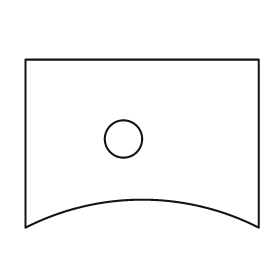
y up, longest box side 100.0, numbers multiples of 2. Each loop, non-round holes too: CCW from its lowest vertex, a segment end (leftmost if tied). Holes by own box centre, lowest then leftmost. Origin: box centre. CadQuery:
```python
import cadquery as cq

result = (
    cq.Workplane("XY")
    .moveTo(-50.0, -36.0)
    .threePointArc((0.0, -24.0), (50.0, -36.0))
    .lineTo(50.0, 36.0)
    .lineTo(-50.0, 36.0)
    .close()
    .moveTo(-8.0, 2.0)
    .circle(8.0)
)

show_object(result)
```